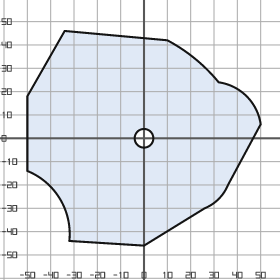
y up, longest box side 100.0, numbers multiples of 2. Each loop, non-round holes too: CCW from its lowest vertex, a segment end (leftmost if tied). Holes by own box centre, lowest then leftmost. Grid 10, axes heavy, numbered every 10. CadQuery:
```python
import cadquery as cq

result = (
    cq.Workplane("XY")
    .moveTo(0.0, -46.0)
    .lineTo(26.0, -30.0)
    .threePointArc((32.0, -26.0), (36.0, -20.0))
    .lineTo(50.0, 6.0)
    .threePointArc((44.0, 18.0), (32.0, 24.0))
    .threePointArc((22.0, 34.0), (10.0, 42.0))
    .lineTo(-34.0, 46.0)
    .lineTo(-50.0, 18.0)
    .lineTo(-50.0, -14.0)
    .threePointArc((-36.0, -26.0), (-32.0, -44.0))
    .close()
    .moveTo(0.0, 0.0)
    .circle(4.0)
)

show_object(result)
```